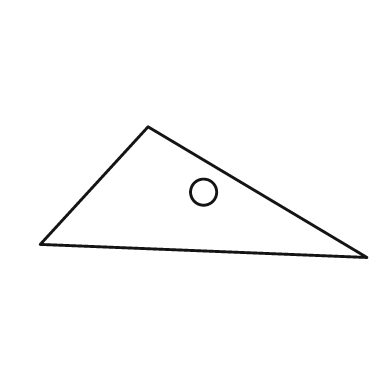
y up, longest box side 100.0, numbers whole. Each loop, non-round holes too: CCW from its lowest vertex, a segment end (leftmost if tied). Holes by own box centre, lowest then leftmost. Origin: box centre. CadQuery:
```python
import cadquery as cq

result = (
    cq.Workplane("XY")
    .moveTo(50.0, -20.0)
    .lineTo(-17.0, 20.0)
    .lineTo(-50.0, -16.0)
    .close()
    .moveTo(0.0, 0.0)
    .circle(4.0)
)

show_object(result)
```